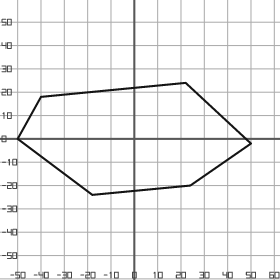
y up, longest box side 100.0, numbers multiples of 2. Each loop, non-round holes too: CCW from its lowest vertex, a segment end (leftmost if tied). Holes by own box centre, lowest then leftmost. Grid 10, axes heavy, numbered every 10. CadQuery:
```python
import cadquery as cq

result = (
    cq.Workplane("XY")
    .moveTo(-18.0, -24.0)
    .lineTo(24.0, -20.0)
    .lineTo(50.0, -2.0)
    .lineTo(22.0, 24.0)
    .lineTo(-40.0, 18.0)
    .lineTo(-50.0, 0.0)
    .close()
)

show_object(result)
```